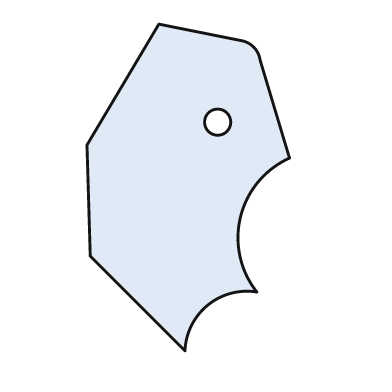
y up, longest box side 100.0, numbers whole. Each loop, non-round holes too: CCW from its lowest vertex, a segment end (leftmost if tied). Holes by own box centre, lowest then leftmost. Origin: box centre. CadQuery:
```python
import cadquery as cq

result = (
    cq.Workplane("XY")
    .moveTo(-1.0, -50.0)
    .threePointArc((6.0, -36.0), (21.0, -32.0))
    .threePointArc((16.0, -9.0), (31.0, 9.0))
    .lineTo(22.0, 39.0)
    .threePointArc((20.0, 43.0), (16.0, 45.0))
    .lineTo(-9.0, 50.0)
    .lineTo(-31.0, 13.0)
    .lineTo(-30.0, -21.0)
    .close()
    .moveTo(9.0, 20.0)
    .circle(4.0)
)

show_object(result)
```